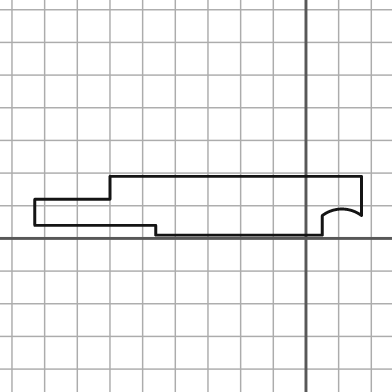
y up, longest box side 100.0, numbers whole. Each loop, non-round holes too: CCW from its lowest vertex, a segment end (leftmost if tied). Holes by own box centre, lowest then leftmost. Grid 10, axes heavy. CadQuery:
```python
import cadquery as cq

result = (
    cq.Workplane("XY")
    .moveTo(-46.0, 1.0)
    .lineTo(5.0, 1.0)
    .lineTo(5.0, 7.0)
    .threePointArc((11.0, 9.0), (17.0, 7.0))
    .lineTo(17.0, 19.0)
    .lineTo(-60.0, 19.0)
    .lineTo(-60.0, 12.0)
    .lineTo(-83.0, 12.0)
    .lineTo(-83.0, 4.0)
    .lineTo(-46.0, 4.0)
    .close()
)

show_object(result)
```